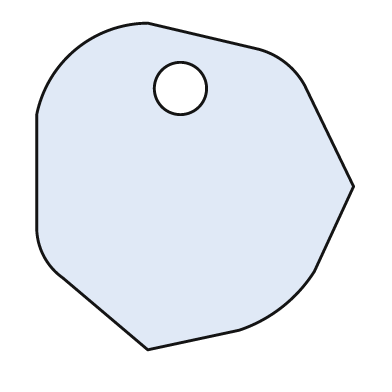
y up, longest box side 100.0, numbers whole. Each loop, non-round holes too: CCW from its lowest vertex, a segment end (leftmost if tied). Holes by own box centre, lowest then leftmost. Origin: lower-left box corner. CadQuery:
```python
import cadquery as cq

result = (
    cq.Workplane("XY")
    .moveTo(34.0, 0.0)
    .lineTo(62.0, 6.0)
    .threePointArc((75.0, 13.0), (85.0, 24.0))
    .lineTo(97.0, 50.0)
    .lineTo(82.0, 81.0)
    .threePointArc((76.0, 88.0), (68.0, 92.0))
    .lineTo(34.0, 100.0)
    .threePointArc((12.0, 92.0), (0.0, 72.0))
    .lineTo(0.0, 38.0)
    .threePointArc((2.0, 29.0), (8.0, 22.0))
    .close()
    .moveTo(44.0, 80.0)
    .circle(8.0)
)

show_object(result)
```